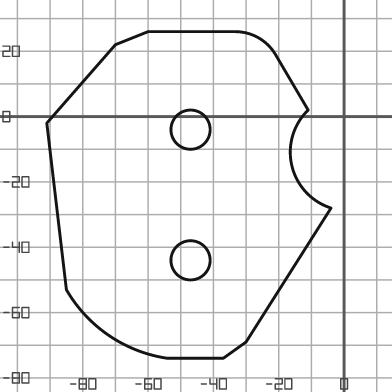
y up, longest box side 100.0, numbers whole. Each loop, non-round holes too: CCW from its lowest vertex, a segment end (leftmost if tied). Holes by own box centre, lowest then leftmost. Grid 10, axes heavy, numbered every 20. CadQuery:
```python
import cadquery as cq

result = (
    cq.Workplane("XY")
    .moveTo(-54.0, -74.0)
    .lineTo(-37.0, -74.0)
    .lineTo(-30.0, -69.0)
    .lineTo(-4.0, -28.0)
    .threePointArc((-16.0, -15.0), (-11.0, 2.0))
    .lineTo(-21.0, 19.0)
    .threePointArc((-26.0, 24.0), (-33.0, 26.0))
    .lineTo(-60.0, 26.0)
    .lineTo(-70.0, 22.0)
    .lineTo(-91.0, -2.0)
    .lineTo(-85.0, -53.0)
    .threePointArc((-72.0, -67.0), (-54.0, -74.0))
    .close()
    .moveTo(-47.0, -44.0)
    .circle(6.0)
    .moveTo(-47.0, -4.0)
    .circle(6.0)
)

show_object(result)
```